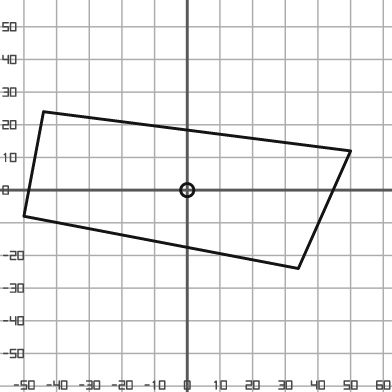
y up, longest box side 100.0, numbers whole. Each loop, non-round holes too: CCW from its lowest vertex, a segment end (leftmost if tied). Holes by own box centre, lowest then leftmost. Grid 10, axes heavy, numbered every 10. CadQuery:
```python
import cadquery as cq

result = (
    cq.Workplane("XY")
    .moveTo(34.0, -24.0)
    .lineTo(50.0, 12.0)
    .lineTo(-44.0, 24.0)
    .lineTo(-50.0, -8.0)
    .close()
    .moveTo(0.0, 0.0)
    .circle(2.0)
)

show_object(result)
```